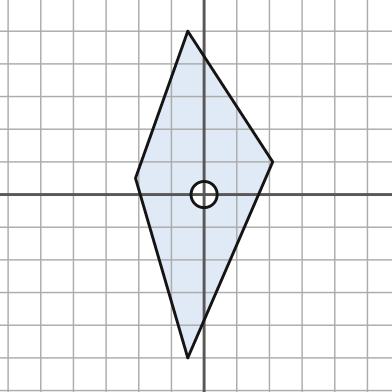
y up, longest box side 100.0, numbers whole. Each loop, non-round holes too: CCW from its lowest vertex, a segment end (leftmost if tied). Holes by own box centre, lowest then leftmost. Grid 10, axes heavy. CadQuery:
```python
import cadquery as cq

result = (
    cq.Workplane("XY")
    .moveTo(-5.0, -50.0)
    .lineTo(21.0, 10.0)
    .lineTo(-5.0, 50.0)
    .lineTo(-21.0, 5.0)
    .close()
    .moveTo(0.0, 0.0)
    .circle(4.0)
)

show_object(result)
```